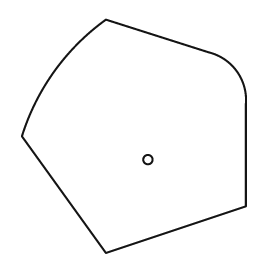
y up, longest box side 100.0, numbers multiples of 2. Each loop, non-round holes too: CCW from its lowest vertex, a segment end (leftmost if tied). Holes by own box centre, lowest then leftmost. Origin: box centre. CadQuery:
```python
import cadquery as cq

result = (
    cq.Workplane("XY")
    .moveTo(-12.0, -50.0)
    .lineTo(48.0, -30.0)
    .lineTo(48.0, 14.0)
    .threePointArc((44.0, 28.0), (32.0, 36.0))
    .lineTo(-12.0, 50.0)
    .threePointArc((-34.0, 28.0), (-48.0, 0.0))
    .close()
    .moveTo(6.0, -10.0)
    .circle(2.0)
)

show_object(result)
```